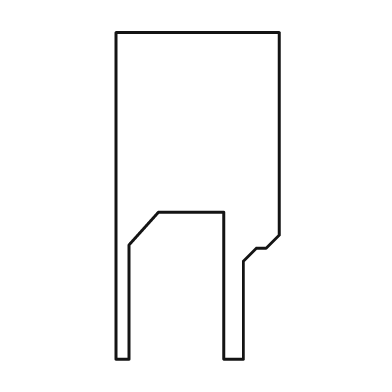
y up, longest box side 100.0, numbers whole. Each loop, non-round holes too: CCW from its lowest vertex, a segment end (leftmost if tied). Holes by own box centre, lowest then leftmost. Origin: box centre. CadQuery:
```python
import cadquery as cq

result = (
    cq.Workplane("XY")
    .moveTo(-25.0, -50.0)
    .lineTo(-21.0, -50.0)
    .lineTo(-21.0, -15.0)
    .lineTo(-12.0, -5.0)
    .lineTo(8.0, -5.0)
    .lineTo(8.0, -50.0)
    .lineTo(14.0, -50.0)
    .lineTo(14.0, -20.0)
    .lineTo(18.0, -16.0)
    .lineTo(21.0, -16.0)
    .lineTo(25.0, -12.0)
    .lineTo(25.0, 50.0)
    .lineTo(-25.0, 50.0)
    .close()
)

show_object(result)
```